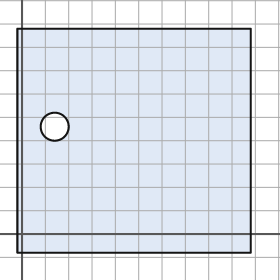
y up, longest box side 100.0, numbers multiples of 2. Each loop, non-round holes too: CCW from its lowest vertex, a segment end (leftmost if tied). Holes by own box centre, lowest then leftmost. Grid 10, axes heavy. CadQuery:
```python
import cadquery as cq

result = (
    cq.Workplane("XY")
    .moveTo(-2.0, -8.0)
    .lineTo(98.0, -8.0)
    .lineTo(98.0, 88.0)
    .lineTo(-2.0, 88.0)
    .close()
    .moveTo(14.0, 46.0)
    .circle(6.0)
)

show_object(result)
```